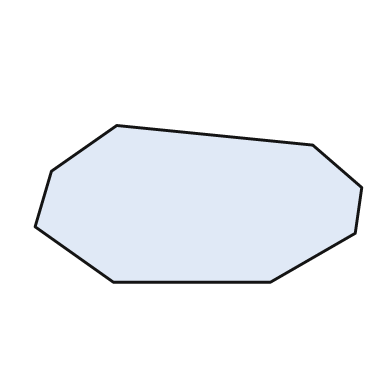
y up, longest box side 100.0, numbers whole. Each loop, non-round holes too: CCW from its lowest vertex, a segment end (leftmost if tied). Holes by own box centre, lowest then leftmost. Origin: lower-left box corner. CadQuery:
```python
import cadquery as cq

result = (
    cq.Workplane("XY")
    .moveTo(24.0, 0.0)
    .lineTo(72.0, 0.0)
    .lineTo(98.0, 15.0)
    .lineTo(100.0, 29.0)
    .lineTo(85.0, 42.0)
    .lineTo(25.0, 48.0)
    .lineTo(5.0, 34.0)
    .lineTo(0.0, 17.0)
    .close()
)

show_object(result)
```